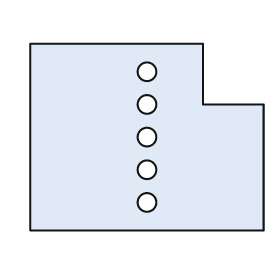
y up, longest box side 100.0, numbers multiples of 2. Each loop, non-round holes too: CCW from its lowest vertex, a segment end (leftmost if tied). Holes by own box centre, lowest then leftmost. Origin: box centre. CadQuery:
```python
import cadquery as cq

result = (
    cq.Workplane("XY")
    .moveTo(-50.0, -40.0)
    .lineTo(50.0, -40.0)
    .lineTo(50.0, 14.0)
    .lineTo(24.0, 14.0)
    .lineTo(24.0, 40.0)
    .lineTo(-50.0, 40.0)
    .close()
    .moveTo(0.0, -28.0)
    .circle(4.0)
    .moveTo(0.0, -14.0)
    .circle(4.0)
    .moveTo(0.0, 0.0)
    .circle(4.0)
    .moveTo(0.0, 14.0)
    .circle(4.0)
    .moveTo(0.0, 28.0)
    .circle(4.0)
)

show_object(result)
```